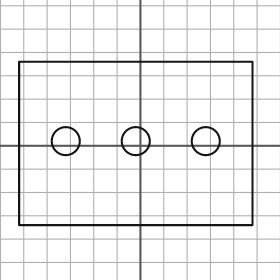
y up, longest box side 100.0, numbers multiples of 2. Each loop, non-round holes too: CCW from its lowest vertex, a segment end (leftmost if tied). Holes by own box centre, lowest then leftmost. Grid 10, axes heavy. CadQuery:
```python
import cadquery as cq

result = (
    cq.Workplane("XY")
    .moveTo(-52.0, -34.0)
    .lineTo(48.0, -34.0)
    .lineTo(48.0, 36.0)
    .lineTo(-52.0, 36.0)
    .close()
    .moveTo(-32.0, 2.0)
    .circle(6.0)
    .moveTo(-2.0, 2.0)
    .circle(6.0)
    .moveTo(28.0, 2.0)
    .circle(6.0)
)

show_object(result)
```